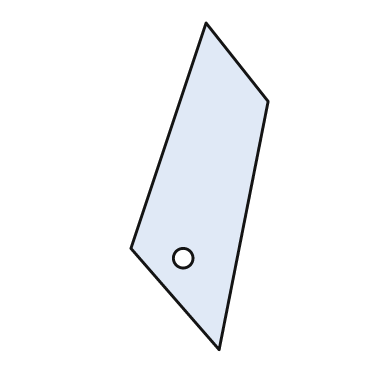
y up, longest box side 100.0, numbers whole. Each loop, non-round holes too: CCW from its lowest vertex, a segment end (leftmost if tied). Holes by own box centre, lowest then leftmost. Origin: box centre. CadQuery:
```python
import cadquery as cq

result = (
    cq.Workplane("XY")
    .moveTo(6.0, -50.0)
    .lineTo(21.0, 26.0)
    .lineTo(2.0, 50.0)
    .lineTo(-21.0, -19.0)
    .close()
    .moveTo(-5.0, -22.0)
    .circle(3.0)
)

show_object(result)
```